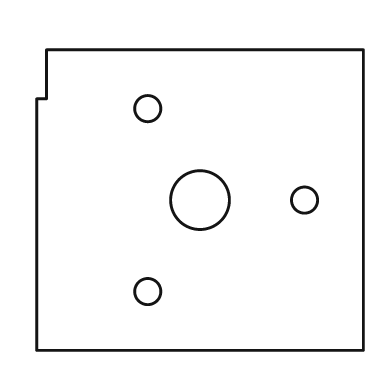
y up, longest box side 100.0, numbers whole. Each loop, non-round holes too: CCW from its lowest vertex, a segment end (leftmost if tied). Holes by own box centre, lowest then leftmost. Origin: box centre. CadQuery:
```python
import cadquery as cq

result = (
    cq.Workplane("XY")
    .moveTo(-50.0, -46.0)
    .lineTo(50.0, -46.0)
    .lineTo(50.0, 46.0)
    .lineTo(-47.0, 46.0)
    .lineTo(-47.0, 31.0)
    .lineTo(-50.0, 31.0)
    .close()
    .moveTo(-16.0, -28.0)
    .circle(4.0)
    .moveTo(0.0, 0.0)
    .circle(9.0)
    .moveTo(32.0, 0.0)
    .circle(4.0)
    .moveTo(-16.0, 28.0)
    .circle(4.0)
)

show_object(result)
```